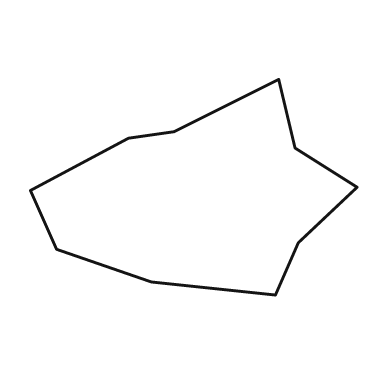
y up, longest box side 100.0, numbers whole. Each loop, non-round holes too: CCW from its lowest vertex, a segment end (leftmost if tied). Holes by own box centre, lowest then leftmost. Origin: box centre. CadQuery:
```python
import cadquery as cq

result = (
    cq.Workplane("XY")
    .moveTo(25.0, -33.0)
    .lineTo(32.0, -17.0)
    .lineTo(50.0, 0.0)
    .lineTo(31.0, 12.0)
    .lineTo(26.0, 33.0)
    .lineTo(-6.0, 17.0)
    .lineTo(-20.0, 15.0)
    .lineTo(-50.0, -1.0)
    .lineTo(-42.0, -19.0)
    .lineTo(-13.0, -29.0)
    .close()
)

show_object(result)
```